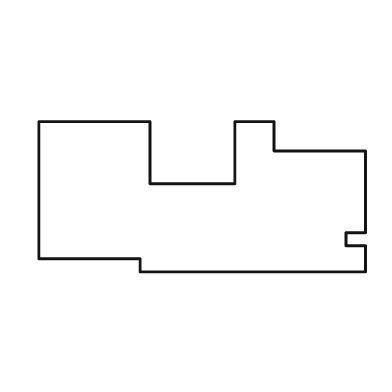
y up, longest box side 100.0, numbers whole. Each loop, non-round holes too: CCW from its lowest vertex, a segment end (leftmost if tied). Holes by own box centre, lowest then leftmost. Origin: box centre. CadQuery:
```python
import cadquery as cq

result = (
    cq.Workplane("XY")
    .moveTo(-19.0, -23.0)
    .lineTo(50.0, -23.0)
    .lineTo(50.0, -15.0)
    .lineTo(44.0, -15.0)
    .lineTo(44.0, -11.0)
    .lineTo(50.0, -11.0)
    .lineTo(50.0, 14.0)
    .lineTo(22.0, 14.0)
    .lineTo(22.0, 23.0)
    .lineTo(10.0, 23.0)
    .lineTo(10.0, 4.0)
    .lineTo(-16.0, 4.0)
    .lineTo(-16.0, 23.0)
    .lineTo(-50.0, 23.0)
    .lineTo(-50.0, -19.0)
    .lineTo(-19.0, -19.0)
    .close()
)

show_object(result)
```